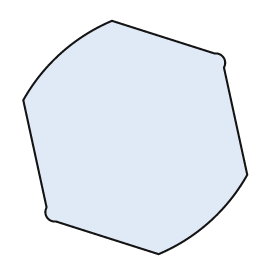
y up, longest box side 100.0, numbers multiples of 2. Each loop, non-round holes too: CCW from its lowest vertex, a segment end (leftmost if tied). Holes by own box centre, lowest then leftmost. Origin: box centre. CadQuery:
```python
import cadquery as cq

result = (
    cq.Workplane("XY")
    .moveTo(10.0, -50.0)
    .threePointArc((32.0, -36.0), (48.0, -16.0))
    .lineTo(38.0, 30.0)
    .threePointArc((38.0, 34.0), (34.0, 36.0))
    .lineTo(-10.0, 50.0)
    .threePointArc((-32.0, 36.0), (-48.0, 16.0))
    .lineTo(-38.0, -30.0)
    .threePointArc((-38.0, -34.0), (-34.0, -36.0))
    .close()
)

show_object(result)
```